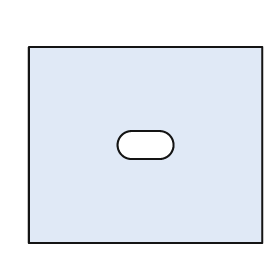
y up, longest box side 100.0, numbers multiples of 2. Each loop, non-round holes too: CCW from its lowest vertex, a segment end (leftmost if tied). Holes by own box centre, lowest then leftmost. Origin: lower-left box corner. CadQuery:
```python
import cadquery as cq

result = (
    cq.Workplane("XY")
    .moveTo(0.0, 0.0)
    .lineTo(100.0, 0.0)
    .lineTo(100.0, 84.0)
    .lineTo(0.0, 84.0)
    .close()
    .moveTo(44.0, 36.0)
    .lineTo(56.0, 36.0)
    .threePointArc((62.0, 42.0), (56.0, 48.0))
    .lineTo(44.0, 48.0)
    .threePointArc((38.0, 42.0), (44.0, 36.0))
    .close()
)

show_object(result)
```